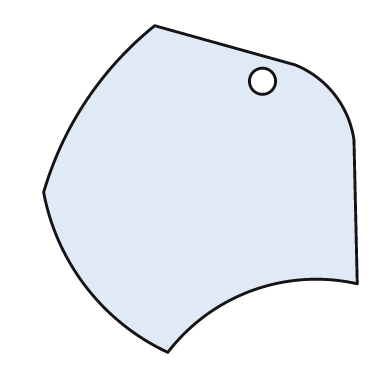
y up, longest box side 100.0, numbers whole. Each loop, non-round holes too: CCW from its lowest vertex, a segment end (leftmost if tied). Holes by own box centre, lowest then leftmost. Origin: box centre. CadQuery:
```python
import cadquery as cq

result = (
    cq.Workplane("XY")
    .moveTo(-10.0, -50.0)
    .threePointArc((16.0, -31.0), (48.0, -29.0))
    .lineTo(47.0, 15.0)
    .threePointArc((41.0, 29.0), (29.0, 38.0))
    .lineTo(-14.0, 50.0)
    .threePointArc((-35.0, 27.0), (-48.0, -1.0))
    .threePointArc((-35.0, -30.0), (-10.0, -50.0))
    .close()
    .moveTo(19.0, 33.0)
    .circle(4.0)
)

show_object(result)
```